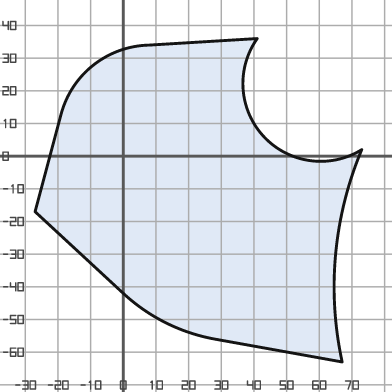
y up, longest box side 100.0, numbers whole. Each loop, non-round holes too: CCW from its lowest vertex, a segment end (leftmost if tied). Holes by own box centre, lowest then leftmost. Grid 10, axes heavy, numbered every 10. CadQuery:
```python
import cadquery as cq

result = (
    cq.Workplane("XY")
    .moveTo(67.0, -63.0)
    .threePointArc((65.0, -30.0), (73.0, 2.0))
    .threePointArc((43.0, 6.0), (41.0, 36.0))
    .lineTo(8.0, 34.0)
    .threePointArc((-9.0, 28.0), (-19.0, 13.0))
    .lineTo(-27.0, -17.0)
    .lineTo(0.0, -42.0)
    .threePointArc((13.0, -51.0), (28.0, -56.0))
    .close()
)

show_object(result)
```